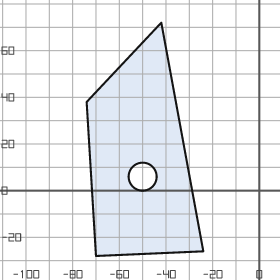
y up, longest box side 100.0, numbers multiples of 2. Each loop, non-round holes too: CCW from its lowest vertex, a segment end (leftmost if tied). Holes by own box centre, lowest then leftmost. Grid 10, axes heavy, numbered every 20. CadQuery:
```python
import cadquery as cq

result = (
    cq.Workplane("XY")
    .moveTo(-70.0, -28.0)
    .lineTo(-24.0, -26.0)
    .lineTo(-42.0, 72.0)
    .lineTo(-74.0, 38.0)
    .close()
    .moveTo(-50.0, 6.0)
    .circle(6.0)
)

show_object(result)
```